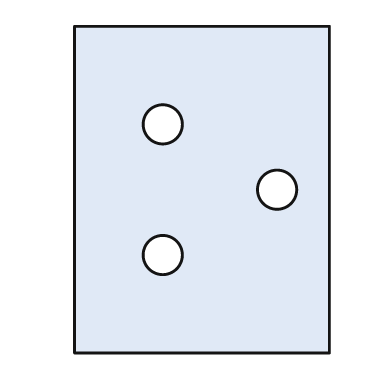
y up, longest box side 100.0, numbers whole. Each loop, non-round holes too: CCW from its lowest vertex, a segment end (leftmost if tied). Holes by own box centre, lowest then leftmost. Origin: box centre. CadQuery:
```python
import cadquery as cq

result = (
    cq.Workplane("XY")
    .moveTo(-39.0, -50.0)
    .lineTo(39.0, -50.0)
    .lineTo(39.0, 50.0)
    .lineTo(-39.0, 50.0)
    .close()
    .moveTo(-12.0, -20.0)
    .circle(6.0)
    .moveTo(23.0, 0.0)
    .circle(6.0)
    .moveTo(-12.0, 20.0)
    .circle(6.0)
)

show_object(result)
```